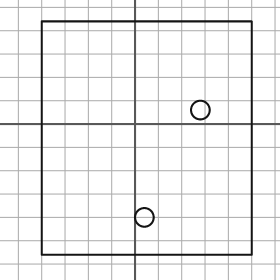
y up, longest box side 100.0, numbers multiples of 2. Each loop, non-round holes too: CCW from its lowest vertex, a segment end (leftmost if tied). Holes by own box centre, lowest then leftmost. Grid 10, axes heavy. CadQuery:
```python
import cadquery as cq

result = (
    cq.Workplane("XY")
    .moveTo(-40.0, -56.0)
    .lineTo(50.0, -56.0)
    .lineTo(50.0, 44.0)
    .lineTo(-40.0, 44.0)
    .close()
    .moveTo(4.0, -40.0)
    .circle(4.0)
    .moveTo(28.0, 6.0)
    .circle(4.0)
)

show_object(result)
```